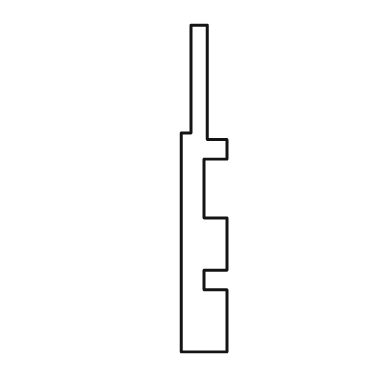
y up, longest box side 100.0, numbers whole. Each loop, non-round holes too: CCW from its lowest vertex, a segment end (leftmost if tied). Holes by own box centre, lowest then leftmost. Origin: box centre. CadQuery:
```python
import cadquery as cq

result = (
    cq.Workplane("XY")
    .moveTo(-7.0, -50.0)
    .lineTo(7.0, -50.0)
    .lineTo(7.0, -31.0)
    .lineTo(0.0, -31.0)
    .lineTo(0.0, -25.0)
    .lineTo(7.0, -25.0)
    .lineTo(7.0, -9.0)
    .lineTo(0.0, -9.0)
    .lineTo(0.0, 9.0)
    .lineTo(7.0, 9.0)
    .lineTo(7.0, 15.0)
    .lineTo(1.0, 15.0)
    .lineTo(1.0, 50.0)
    .lineTo(-4.0, 50.0)
    .lineTo(-4.0, 17.0)
    .lineTo(-7.0, 17.0)
    .close()
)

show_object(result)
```